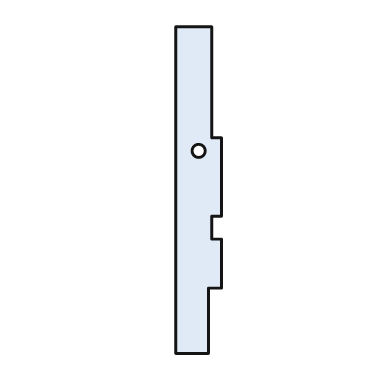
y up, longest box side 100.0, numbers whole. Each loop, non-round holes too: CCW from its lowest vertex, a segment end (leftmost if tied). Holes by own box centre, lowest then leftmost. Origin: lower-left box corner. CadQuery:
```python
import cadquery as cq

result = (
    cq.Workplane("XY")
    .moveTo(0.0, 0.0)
    .lineTo(10.0, 0.0)
    .lineTo(10.0, 20.0)
    .lineTo(14.0, 20.0)
    .lineTo(14.0, 35.0)
    .lineTo(11.0, 35.0)
    .lineTo(11.0, 42.0)
    .lineTo(14.0, 42.0)
    .lineTo(14.0, 66.0)
    .lineTo(11.0, 66.0)
    .lineTo(11.0, 100.0)
    .lineTo(0.0, 100.0)
    .close()
    .moveTo(7.0, 62.0)
    .circle(2.0)
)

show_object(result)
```